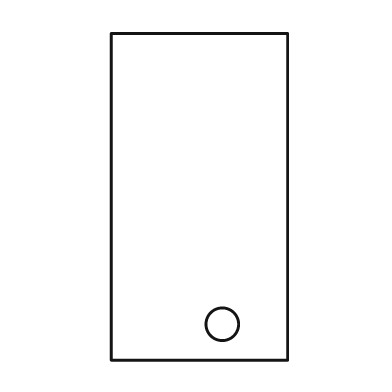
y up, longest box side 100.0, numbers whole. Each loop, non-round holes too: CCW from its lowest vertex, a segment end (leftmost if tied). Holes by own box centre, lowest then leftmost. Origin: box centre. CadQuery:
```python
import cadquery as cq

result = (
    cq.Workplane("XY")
    .moveTo(-27.0, -50.0)
    .lineTo(27.0, -50.0)
    .lineTo(27.0, 50.0)
    .lineTo(-27.0, 50.0)
    .close()
    .moveTo(7.0, -39.0)
    .circle(5.0)
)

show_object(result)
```